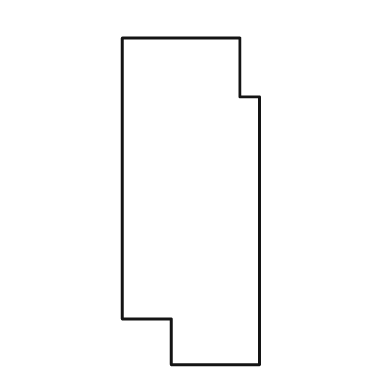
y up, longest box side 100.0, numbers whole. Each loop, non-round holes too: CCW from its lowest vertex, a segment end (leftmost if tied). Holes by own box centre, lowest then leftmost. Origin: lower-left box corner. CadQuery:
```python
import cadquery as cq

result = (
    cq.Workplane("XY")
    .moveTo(15.0, 0.0)
    .lineTo(42.0, 0.0)
    .lineTo(42.0, 82.0)
    .lineTo(36.0, 82.0)
    .lineTo(36.0, 100.0)
    .lineTo(0.0, 100.0)
    .lineTo(0.0, 14.0)
    .lineTo(15.0, 14.0)
    .close()
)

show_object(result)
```